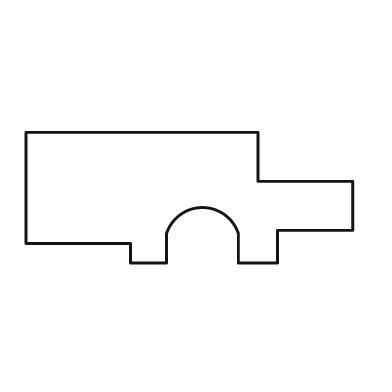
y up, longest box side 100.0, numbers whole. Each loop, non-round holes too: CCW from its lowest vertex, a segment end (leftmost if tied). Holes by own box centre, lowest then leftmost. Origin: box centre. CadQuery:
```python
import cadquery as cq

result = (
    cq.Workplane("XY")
    .moveTo(-18.0, -20.0)
    .lineTo(-7.0, -20.0)
    .lineTo(-7.0, -11.0)
    .threePointArc((4.0, -3.0), (15.0, -11.0))
    .lineTo(15.0, -20.0)
    .lineTo(27.0, -20.0)
    .lineTo(27.0, -10.0)
    .lineTo(50.0, -10.0)
    .lineTo(50.0, 5.0)
    .lineTo(21.0, 5.0)
    .lineTo(21.0, 20.0)
    .lineTo(-50.0, 20.0)
    .lineTo(-50.0, -14.0)
    .lineTo(-18.0, -14.0)
    .close()
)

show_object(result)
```